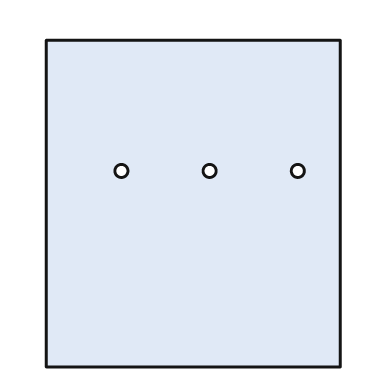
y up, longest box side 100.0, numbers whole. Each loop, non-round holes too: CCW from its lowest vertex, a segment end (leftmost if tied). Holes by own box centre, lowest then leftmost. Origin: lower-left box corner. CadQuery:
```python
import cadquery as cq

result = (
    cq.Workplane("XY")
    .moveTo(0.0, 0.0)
    .lineTo(90.0, 0.0)
    .lineTo(90.0, 100.0)
    .lineTo(0.0, 100.0)
    .close()
    .moveTo(23.0, 60.0)
    .circle(2.0)
    .moveTo(50.0, 60.0)
    .circle(2.0)
    .moveTo(77.0, 60.0)
    .circle(2.0)
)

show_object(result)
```